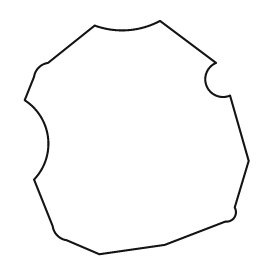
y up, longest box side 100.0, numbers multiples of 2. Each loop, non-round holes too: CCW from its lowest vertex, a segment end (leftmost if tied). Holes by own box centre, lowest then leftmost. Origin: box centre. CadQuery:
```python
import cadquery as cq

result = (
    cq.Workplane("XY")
    .moveTo(-16.0, -50.0)
    .lineTo(12.0, -46.0)
    .lineTo(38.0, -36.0)
    .threePointArc((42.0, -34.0), (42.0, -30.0))
    .lineTo(48.0, -10.0)
    .lineTo(40.0, 18.0)
    .threePointArc((30.0, 22.0), (34.0, 32.0))
    .lineTo(10.0, 50.0)
    .threePointArc((-4.0, 46.0), (-18.0, 48.0))
    .lineTo(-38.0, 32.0)
    .threePointArc((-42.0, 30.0), (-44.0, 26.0))
    .lineTo(-48.0, 16.0)
    .threePointArc((-38.0, 0.0), (-44.0, -18.0))
    .lineTo(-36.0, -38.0)
    .threePointArc((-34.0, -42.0), (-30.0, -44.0))
    .close()
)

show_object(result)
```